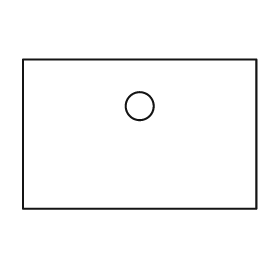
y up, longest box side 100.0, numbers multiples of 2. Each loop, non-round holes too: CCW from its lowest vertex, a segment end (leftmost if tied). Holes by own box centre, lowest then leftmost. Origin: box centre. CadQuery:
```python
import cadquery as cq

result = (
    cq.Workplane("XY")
    .moveTo(-50.0, -32.0)
    .lineTo(50.0, -32.0)
    .lineTo(50.0, 32.0)
    .lineTo(-50.0, 32.0)
    .close()
    .moveTo(0.0, 12.0)
    .circle(6.0)
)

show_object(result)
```